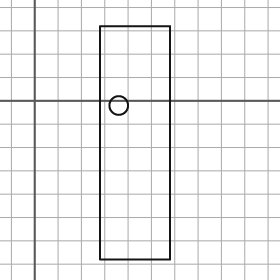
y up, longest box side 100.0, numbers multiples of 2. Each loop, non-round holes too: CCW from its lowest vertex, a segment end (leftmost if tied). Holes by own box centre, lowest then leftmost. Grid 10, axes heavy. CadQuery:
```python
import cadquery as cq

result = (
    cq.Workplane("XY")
    .moveTo(28.0, -68.0)
    .lineTo(58.0, -68.0)
    .lineTo(58.0, 32.0)
    .lineTo(28.0, 32.0)
    .close()
    .moveTo(36.0, -2.0)
    .circle(4.0)
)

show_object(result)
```